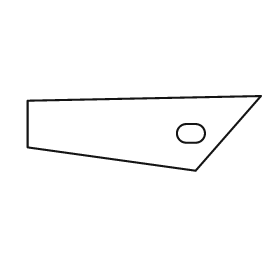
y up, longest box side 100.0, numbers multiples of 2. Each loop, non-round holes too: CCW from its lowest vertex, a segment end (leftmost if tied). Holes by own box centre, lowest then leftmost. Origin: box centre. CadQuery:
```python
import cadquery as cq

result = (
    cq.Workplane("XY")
    .moveTo(22.0, -16.0)
    .lineTo(50.0, 16.0)
    .lineTo(-50.0, 14.0)
    .lineTo(-50.0, -6.0)
    .close()
    .moveTo(18.0, -4.0)
    .lineTo(22.0, -4.0)
    .threePointArc((26.0, 0.0), (22.0, 4.0))
    .lineTo(18.0, 4.0)
    .threePointArc((14.0, 0.0), (18.0, -4.0))
    .close()
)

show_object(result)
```